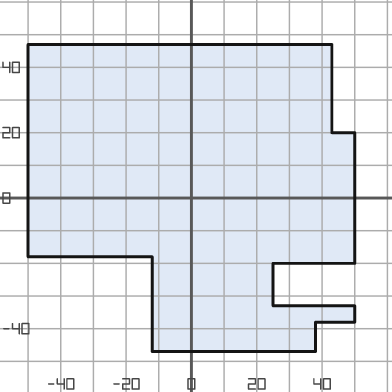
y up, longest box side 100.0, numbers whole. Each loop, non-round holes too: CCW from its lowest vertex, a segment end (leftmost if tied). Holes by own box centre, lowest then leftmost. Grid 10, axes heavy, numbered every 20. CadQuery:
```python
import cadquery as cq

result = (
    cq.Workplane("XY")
    .moveTo(-12.0, -47.0)
    .lineTo(38.0, -47.0)
    .lineTo(38.0, -38.0)
    .lineTo(50.0, -38.0)
    .lineTo(50.0, -33.0)
    .lineTo(25.0, -33.0)
    .lineTo(25.0, -20.0)
    .lineTo(50.0, -20.0)
    .lineTo(50.0, 20.0)
    .lineTo(43.0, 20.0)
    .lineTo(43.0, 47.0)
    .lineTo(-50.0, 47.0)
    .lineTo(-50.0, -18.0)
    .lineTo(-12.0, -18.0)
    .close()
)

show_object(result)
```